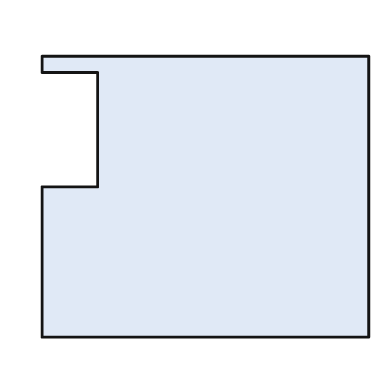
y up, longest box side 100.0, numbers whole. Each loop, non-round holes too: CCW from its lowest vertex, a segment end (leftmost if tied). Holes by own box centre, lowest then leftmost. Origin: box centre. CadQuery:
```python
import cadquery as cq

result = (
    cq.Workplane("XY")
    .moveTo(-50.0, -43.0)
    .lineTo(50.0, -43.0)
    .lineTo(50.0, 43.0)
    .lineTo(-50.0, 43.0)
    .lineTo(-50.0, 38.0)
    .lineTo(-33.0, 38.0)
    .lineTo(-33.0, 3.0)
    .lineTo(-50.0, 3.0)
    .close()
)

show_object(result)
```